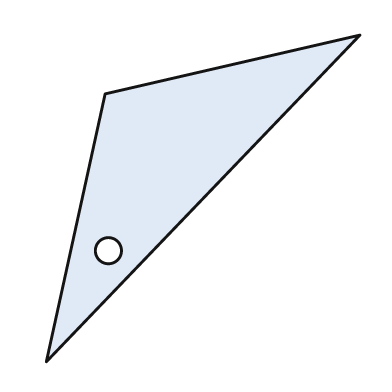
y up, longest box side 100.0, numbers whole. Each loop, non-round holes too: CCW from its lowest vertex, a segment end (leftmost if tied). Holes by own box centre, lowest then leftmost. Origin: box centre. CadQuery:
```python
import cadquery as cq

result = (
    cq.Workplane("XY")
    .moveTo(-48.0, -50.0)
    .lineTo(48.0, 50.0)
    .lineTo(-30.0, 32.0)
    .close()
    .moveTo(-29.0, -16.0)
    .circle(4.0)
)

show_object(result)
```